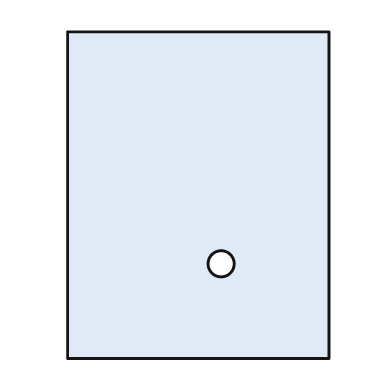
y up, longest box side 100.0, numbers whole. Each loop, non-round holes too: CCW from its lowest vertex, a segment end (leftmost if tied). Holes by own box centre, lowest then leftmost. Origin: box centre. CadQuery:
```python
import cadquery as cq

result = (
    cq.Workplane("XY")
    .moveTo(-40.0, -50.0)
    .lineTo(40.0, -50.0)
    .lineTo(40.0, 50.0)
    .lineTo(-40.0, 50.0)
    .close()
    .moveTo(7.0, -21.0)
    .circle(4.0)
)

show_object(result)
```